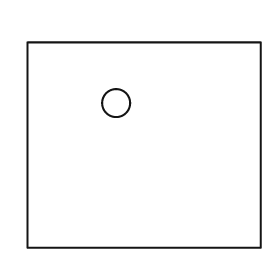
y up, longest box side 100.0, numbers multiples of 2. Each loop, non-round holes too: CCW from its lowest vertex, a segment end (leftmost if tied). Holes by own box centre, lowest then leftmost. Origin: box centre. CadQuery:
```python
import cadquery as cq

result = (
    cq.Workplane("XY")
    .moveTo(-50.0, -44.0)
    .lineTo(50.0, -44.0)
    .lineTo(50.0, 44.0)
    .lineTo(-50.0, 44.0)
    .close()
    .moveTo(-12.0, 18.0)
    .circle(6.0)
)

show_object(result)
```